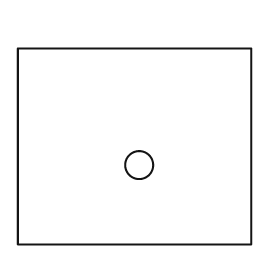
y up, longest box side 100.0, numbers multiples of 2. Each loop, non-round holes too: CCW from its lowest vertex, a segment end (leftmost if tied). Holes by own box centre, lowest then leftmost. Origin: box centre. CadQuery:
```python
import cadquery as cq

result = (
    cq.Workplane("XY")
    .moveTo(-50.0, -42.0)
    .lineTo(50.0, -42.0)
    .lineTo(50.0, 42.0)
    .lineTo(-50.0, 42.0)
    .close()
    .moveTo(2.0, -8.0)
    .circle(6.0)
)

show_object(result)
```